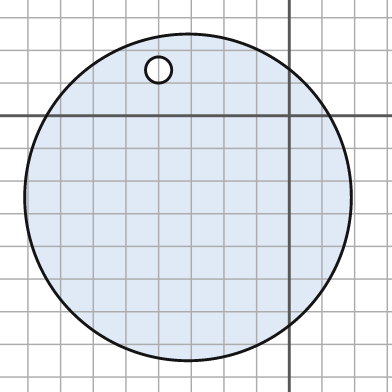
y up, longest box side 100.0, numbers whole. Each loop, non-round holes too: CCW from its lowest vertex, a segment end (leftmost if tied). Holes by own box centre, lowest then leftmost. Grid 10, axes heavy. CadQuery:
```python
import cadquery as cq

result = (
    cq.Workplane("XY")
    .moveTo(-31.0, -25.0)
    .circle(50.0)
    .moveTo(-40.0, 14.0)
    .circle(4.0)
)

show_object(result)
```